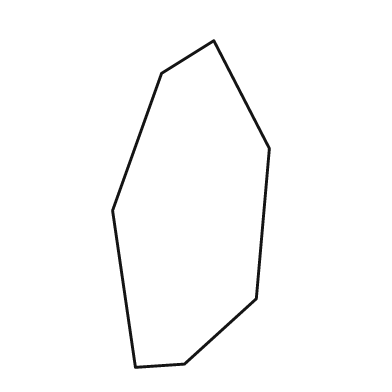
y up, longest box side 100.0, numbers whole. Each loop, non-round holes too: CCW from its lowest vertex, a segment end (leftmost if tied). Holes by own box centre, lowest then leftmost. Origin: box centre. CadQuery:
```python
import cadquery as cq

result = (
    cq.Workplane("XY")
    .moveTo(-17.0, -50.0)
    .lineTo(-2.0, -49.0)
    .lineTo(20.0, -29.0)
    .lineTo(24.0, 17.0)
    .lineTo(7.0, 50.0)
    .lineTo(-9.0, 40.0)
    .lineTo(-24.0, -2.0)
    .close()
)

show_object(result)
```